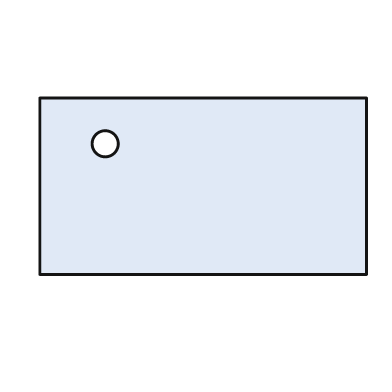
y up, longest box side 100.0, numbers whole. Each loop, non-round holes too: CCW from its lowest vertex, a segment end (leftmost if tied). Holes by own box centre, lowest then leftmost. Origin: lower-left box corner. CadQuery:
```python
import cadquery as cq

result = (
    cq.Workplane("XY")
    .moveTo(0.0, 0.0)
    .lineTo(100.0, 0.0)
    .lineTo(100.0, 54.0)
    .lineTo(0.0, 54.0)
    .close()
    .moveTo(20.0, 40.0)
    .circle(4.0)
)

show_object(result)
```